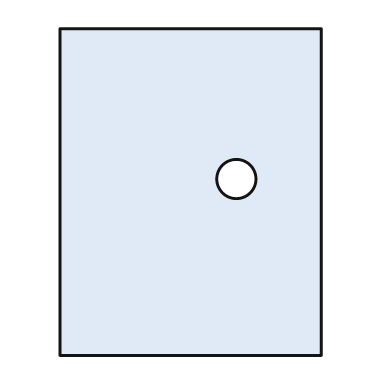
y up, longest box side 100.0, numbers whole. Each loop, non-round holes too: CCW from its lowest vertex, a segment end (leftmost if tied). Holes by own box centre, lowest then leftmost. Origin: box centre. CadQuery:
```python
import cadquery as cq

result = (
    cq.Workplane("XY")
    .moveTo(-40.0, -50.0)
    .lineTo(40.0, -50.0)
    .lineTo(40.0, 50.0)
    .lineTo(-40.0, 50.0)
    .close()
    .moveTo(14.0, 4.0)
    .circle(6.0)
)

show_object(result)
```